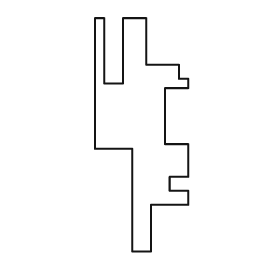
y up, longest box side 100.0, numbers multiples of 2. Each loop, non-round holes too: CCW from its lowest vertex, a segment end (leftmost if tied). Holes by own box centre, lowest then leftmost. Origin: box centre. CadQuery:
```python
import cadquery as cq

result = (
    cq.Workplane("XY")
    .moveTo(-4.0, -50.0)
    .lineTo(4.0, -50.0)
    .lineTo(4.0, -30.0)
    .lineTo(20.0, -30.0)
    .lineTo(20.0, -24.0)
    .lineTo(12.0, -24.0)
    .lineTo(12.0, -18.0)
    .lineTo(20.0, -18.0)
    .lineTo(20.0, -4.0)
    .lineTo(10.0, -4.0)
    .lineTo(10.0, 20.0)
    .lineTo(20.0, 20.0)
    .lineTo(20.0, 24.0)
    .lineTo(16.0, 24.0)
    .lineTo(16.0, 30.0)
    .lineTo(2.0, 30.0)
    .lineTo(2.0, 50.0)
    .lineTo(-8.0, 50.0)
    .lineTo(-8.0, 22.0)
    .lineTo(-16.0, 22.0)
    .lineTo(-16.0, 50.0)
    .lineTo(-20.0, 50.0)
    .lineTo(-20.0, -6.0)
    .lineTo(-4.0, -6.0)
    .close()
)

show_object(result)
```